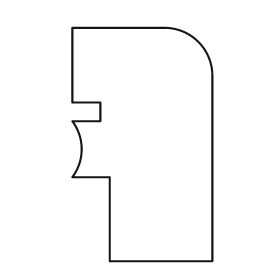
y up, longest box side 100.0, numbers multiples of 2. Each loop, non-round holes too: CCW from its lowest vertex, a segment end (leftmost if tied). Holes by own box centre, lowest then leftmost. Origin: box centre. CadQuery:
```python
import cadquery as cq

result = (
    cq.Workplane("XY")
    .moveTo(-14.0, -50.0)
    .lineTo(30.0, -50.0)
    .lineTo(30.0, 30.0)
    .threePointArc((24.0, 44.0), (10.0, 50.0))
    .lineTo(-30.0, 50.0)
    .lineTo(-30.0, 18.0)
    .lineTo(-18.0, 18.0)
    .lineTo(-18.0, 10.0)
    .lineTo(-30.0, 10.0)
    .threePointArc((-26.0, -2.0), (-30.0, -14.0))
    .lineTo(-14.0, -14.0)
    .close()
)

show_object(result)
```